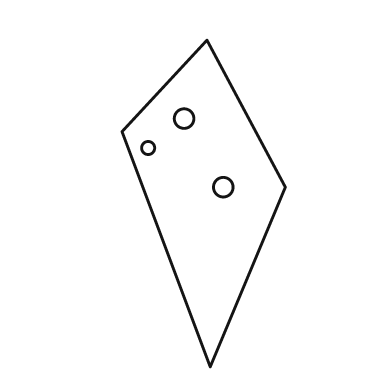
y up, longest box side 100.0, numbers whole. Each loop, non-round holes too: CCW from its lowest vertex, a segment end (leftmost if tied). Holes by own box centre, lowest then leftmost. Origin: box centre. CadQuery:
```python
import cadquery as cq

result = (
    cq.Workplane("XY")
    .moveTo(2.0, -50.0)
    .lineTo(25.0, 5.0)
    .lineTo(1.0, 50.0)
    .lineTo(-25.0, 22.0)
    .close()
    .moveTo(6.0, 5.0)
    .circle(3.0)
    .moveTo(-17.0, 17.0)
    .circle(2.0)
    .moveTo(-6.0, 26.0)
    .circle(3.0)
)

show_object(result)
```